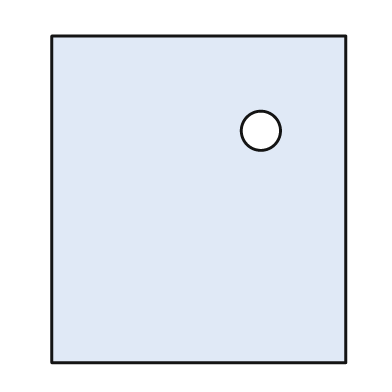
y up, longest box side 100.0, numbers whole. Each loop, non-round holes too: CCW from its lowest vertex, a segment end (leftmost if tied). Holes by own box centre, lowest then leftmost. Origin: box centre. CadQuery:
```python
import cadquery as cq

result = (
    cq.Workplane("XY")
    .moveTo(-45.0, -50.0)
    .lineTo(45.0, -50.0)
    .lineTo(45.0, 50.0)
    .lineTo(-45.0, 50.0)
    .close()
    .moveTo(19.0, 21.0)
    .circle(6.0)
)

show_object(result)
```